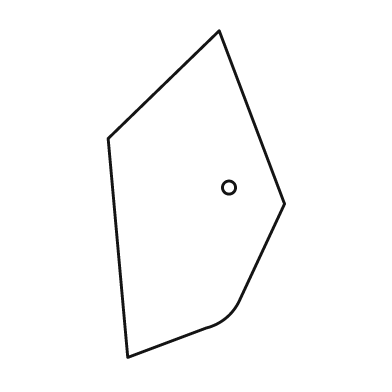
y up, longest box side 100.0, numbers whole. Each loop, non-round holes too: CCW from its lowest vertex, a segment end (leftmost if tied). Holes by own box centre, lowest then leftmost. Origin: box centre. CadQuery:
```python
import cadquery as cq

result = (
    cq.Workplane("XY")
    .moveTo(-21.0, -50.0)
    .lineTo(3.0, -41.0)
    .threePointArc((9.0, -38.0), (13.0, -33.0))
    .lineTo(27.0, -3.0)
    .lineTo(7.0, 50.0)
    .lineTo(-27.0, 17.0)
    .close()
    .moveTo(10.0, 2.0)
    .circle(2.0)
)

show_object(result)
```